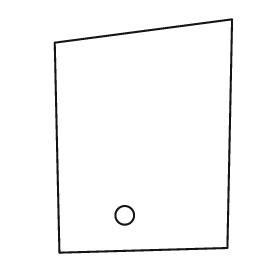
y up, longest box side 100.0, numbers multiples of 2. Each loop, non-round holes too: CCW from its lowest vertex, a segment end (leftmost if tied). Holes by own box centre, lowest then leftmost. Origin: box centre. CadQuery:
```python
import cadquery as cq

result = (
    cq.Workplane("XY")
    .moveTo(-36.0, -50.0)
    .lineTo(36.0, -48.0)
    .lineTo(38.0, 50.0)
    .lineTo(-38.0, 40.0)
    .close()
    .moveTo(-8.0, -34.0)
    .circle(4.0)
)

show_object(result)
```